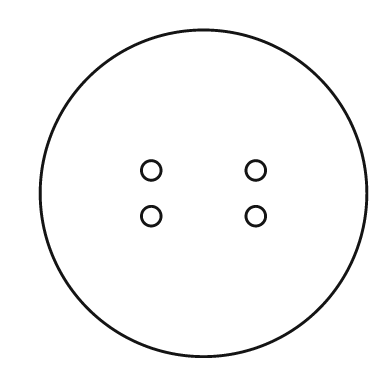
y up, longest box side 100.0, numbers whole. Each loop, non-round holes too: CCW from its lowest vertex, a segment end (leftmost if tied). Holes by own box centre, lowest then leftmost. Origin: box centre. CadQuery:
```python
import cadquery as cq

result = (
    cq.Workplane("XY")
    .moveTo(0.0, 0.0)
    .circle(50.0)
    .moveTo(-16.0, -7.0)
    .circle(3.0)
    .moveTo(16.0, -7.0)
    .circle(3.0)
    .moveTo(-16.0, 7.0)
    .circle(3.0)
    .moveTo(16.0, 7.0)
    .circle(3.0)
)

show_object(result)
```